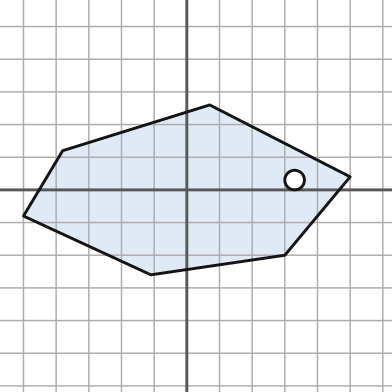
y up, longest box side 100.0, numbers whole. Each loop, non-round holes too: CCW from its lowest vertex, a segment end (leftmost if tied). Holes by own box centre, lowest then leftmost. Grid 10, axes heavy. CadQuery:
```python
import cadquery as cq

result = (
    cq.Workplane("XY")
    .moveTo(-11.0, -26.0)
    .lineTo(30.0, -20.0)
    .lineTo(50.0, 4.0)
    .lineTo(7.0, 26.0)
    .lineTo(-38.0, 12.0)
    .lineTo(-50.0, -8.0)
    .close()
    .moveTo(33.0, 3.0)
    .circle(3.0)
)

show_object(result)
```